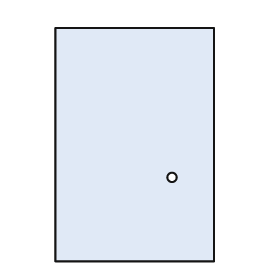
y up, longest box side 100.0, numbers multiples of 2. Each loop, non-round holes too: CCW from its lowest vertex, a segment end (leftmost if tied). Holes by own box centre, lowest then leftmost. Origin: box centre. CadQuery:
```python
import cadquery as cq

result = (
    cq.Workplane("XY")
    .moveTo(-34.0, -50.0)
    .lineTo(34.0, -50.0)
    .lineTo(34.0, 50.0)
    .lineTo(-34.0, 50.0)
    .close()
    .moveTo(16.0, -14.0)
    .circle(2.0)
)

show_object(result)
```